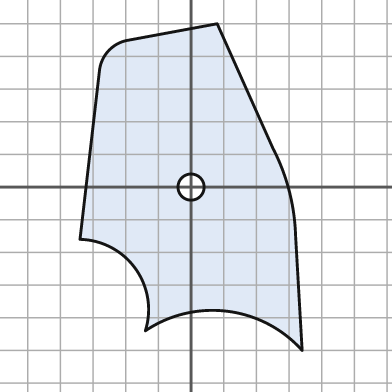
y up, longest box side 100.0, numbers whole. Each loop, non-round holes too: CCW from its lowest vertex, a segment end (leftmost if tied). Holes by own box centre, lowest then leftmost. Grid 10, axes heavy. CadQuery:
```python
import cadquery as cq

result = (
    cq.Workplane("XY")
    .moveTo(34.0, -50.0)
    .lineTo(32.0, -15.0)
    .threePointArc((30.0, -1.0), (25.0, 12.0))
    .lineTo(8.0, 50.0)
    .lineTo(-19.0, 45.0)
    .threePointArc((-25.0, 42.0), (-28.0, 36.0))
    .lineTo(-34.0, -16.0)
    .threePointArc((-17.0, -25.0), (-14.0, -44.0))
    .threePointArc((11.0, -38.0), (34.0, -50.0))
    .close()
    .moveTo(0.0, 0.0)
    .circle(4.0)
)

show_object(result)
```